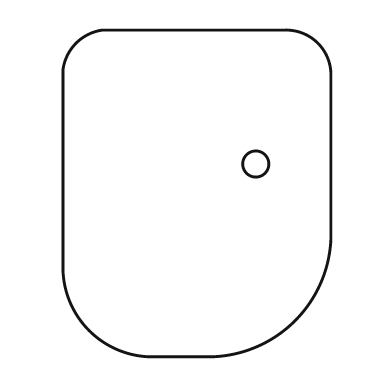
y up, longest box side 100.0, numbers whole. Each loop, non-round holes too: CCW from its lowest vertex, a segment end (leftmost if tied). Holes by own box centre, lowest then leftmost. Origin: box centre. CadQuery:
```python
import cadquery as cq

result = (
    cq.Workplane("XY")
    .moveTo(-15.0, -50.0)
    .lineTo(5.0, -50.0)
    .threePointArc((30.0, -39.0), (41.0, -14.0))
    .lineTo(41.0, 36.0)
    .threePointArc((37.0, 46.0), (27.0, 50.0))
    .lineTo(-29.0, 50.0)
    .threePointArc((-37.0, 46.0), (-41.0, 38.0))
    .lineTo(-41.0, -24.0)
    .threePointArc((-33.0, -42.0), (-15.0, -50.0))
    .close()
    .moveTo(18.0, 9.0)
    .circle(4.0)
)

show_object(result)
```